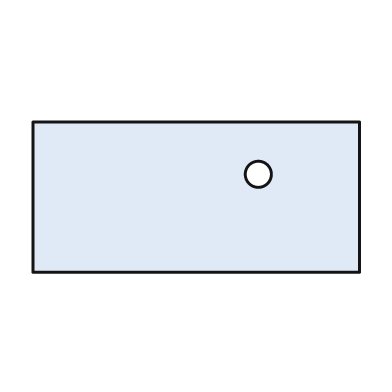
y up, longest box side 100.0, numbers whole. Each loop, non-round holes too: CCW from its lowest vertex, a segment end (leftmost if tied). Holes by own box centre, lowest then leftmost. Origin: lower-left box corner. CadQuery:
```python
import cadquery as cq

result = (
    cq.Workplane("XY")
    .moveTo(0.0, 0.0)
    .lineTo(100.0, 0.0)
    .lineTo(100.0, 46.0)
    .lineTo(0.0, 46.0)
    .close()
    .moveTo(69.0, 30.0)
    .circle(4.0)
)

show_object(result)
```